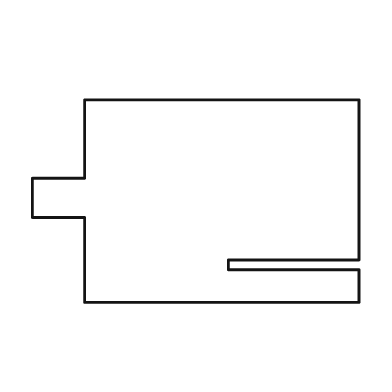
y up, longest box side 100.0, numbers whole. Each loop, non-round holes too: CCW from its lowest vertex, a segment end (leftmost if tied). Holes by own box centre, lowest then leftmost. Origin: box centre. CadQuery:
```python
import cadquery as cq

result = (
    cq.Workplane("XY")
    .moveTo(-34.0, -31.0)
    .lineTo(50.0, -31.0)
    .lineTo(50.0, -21.0)
    .lineTo(10.0, -21.0)
    .lineTo(10.0, -18.0)
    .lineTo(50.0, -18.0)
    .lineTo(50.0, 31.0)
    .lineTo(-34.0, 31.0)
    .lineTo(-34.0, 7.0)
    .lineTo(-50.0, 7.0)
    .lineTo(-50.0, -5.0)
    .lineTo(-34.0, -5.0)
    .close()
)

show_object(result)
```